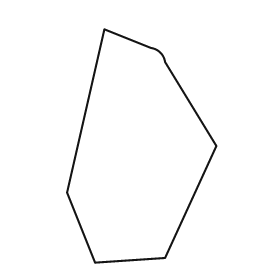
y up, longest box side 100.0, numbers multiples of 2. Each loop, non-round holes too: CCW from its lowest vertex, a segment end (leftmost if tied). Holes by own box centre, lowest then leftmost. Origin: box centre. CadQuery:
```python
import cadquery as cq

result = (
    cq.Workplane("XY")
    .moveTo(-20.0, -50.0)
    .lineTo(10.0, -48.0)
    .lineTo(32.0, 0.0)
    .lineTo(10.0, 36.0)
    .threePointArc((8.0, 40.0), (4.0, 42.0))
    .lineTo(-16.0, 50.0)
    .lineTo(-32.0, -20.0)
    .close()
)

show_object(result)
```